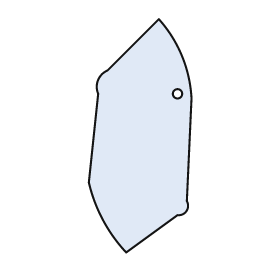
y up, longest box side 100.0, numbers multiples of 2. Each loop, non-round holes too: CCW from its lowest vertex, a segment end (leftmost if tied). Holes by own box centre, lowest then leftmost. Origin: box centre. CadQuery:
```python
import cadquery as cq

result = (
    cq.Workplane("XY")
    .moveTo(-6.0, -50.0)
    .lineTo(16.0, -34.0)
    .threePointArc((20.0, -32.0), (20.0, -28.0))
    .lineTo(22.0, 16.0)
    .threePointArc((18.0, 34.0), (8.0, 50.0))
    .lineTo(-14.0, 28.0)
    .threePointArc((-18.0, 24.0), (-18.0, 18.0))
    .lineTo(-22.0, -20.0)
    .threePointArc((-16.0, -36.0), (-6.0, -50.0))
    .close()
    .moveTo(16.0, 18.0)
    .circle(2.0)
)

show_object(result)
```